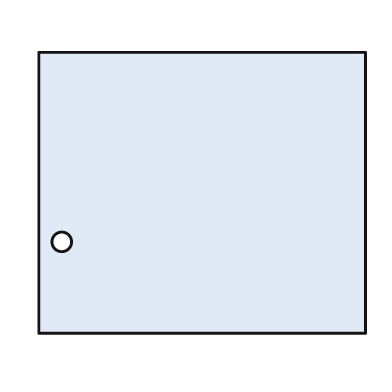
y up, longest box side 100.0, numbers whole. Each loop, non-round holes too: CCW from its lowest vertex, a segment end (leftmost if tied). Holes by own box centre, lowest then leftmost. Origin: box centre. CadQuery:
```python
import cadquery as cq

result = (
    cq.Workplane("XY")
    .moveTo(-50.0, -43.0)
    .lineTo(50.0, -43.0)
    .lineTo(50.0, 43.0)
    .lineTo(-50.0, 43.0)
    .close()
    .moveTo(-43.0, -15.0)
    .circle(3.0)
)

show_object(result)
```